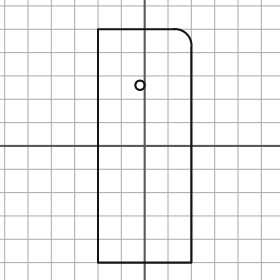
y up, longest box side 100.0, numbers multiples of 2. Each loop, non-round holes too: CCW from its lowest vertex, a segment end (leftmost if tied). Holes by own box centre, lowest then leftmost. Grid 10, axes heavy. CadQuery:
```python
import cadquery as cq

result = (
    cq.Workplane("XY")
    .moveTo(-20.0, -50.0)
    .lineTo(20.0, -50.0)
    .lineTo(20.0, 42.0)
    .threePointArc((18.0, 48.0), (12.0, 50.0))
    .lineTo(-20.0, 50.0)
    .close()
    .moveTo(-2.0, 26.0)
    .circle(2.0)
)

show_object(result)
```